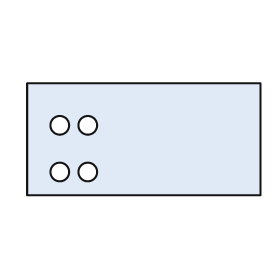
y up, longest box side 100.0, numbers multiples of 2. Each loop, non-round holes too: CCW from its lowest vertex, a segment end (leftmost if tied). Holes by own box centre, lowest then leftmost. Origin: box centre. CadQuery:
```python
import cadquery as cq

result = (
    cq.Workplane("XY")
    .moveTo(-50.0, -24.0)
    .lineTo(50.0, -24.0)
    .lineTo(50.0, 24.0)
    .lineTo(-50.0, 24.0)
    .close()
    .moveTo(-36.0, -14.0)
    .circle(4.0)
    .moveTo(-24.0, -14.0)
    .circle(4.0)
    .moveTo(-36.0, 6.0)
    .circle(4.0)
    .moveTo(-24.0, 6.0)
    .circle(4.0)
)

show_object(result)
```